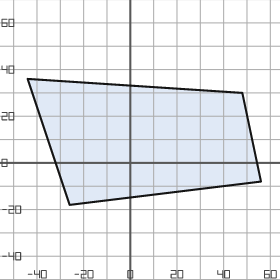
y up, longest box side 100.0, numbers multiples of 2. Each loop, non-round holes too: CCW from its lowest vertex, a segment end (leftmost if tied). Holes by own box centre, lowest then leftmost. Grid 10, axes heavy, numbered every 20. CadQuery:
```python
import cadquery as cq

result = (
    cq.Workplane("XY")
    .moveTo(-26.0, -18.0)
    .lineTo(56.0, -8.0)
    .lineTo(48.0, 30.0)
    .lineTo(-44.0, 36.0)
    .close()
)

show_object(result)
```